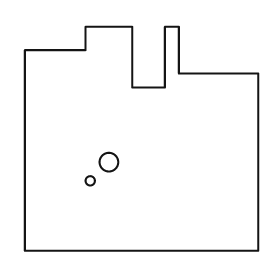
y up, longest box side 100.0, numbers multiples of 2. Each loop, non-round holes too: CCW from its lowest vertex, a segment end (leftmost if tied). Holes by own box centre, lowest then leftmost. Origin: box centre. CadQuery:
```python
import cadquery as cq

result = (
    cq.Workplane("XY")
    .moveTo(-50.0, -48.0)
    .lineTo(50.0, -48.0)
    .lineTo(50.0, 28.0)
    .lineTo(16.0, 28.0)
    .lineTo(16.0, 48.0)
    .lineTo(10.0, 48.0)
    .lineTo(10.0, 22.0)
    .lineTo(-4.0, 22.0)
    .lineTo(-4.0, 48.0)
    .lineTo(-24.0, 48.0)
    .lineTo(-24.0, 38.0)
    .lineTo(-50.0, 38.0)
    .close()
    .moveTo(-22.0, -18.0)
    .circle(2.0)
    .moveTo(-14.0, -10.0)
    .circle(4.0)
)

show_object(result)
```